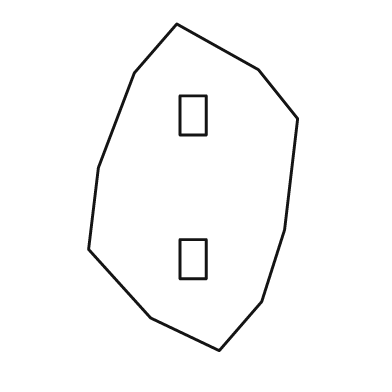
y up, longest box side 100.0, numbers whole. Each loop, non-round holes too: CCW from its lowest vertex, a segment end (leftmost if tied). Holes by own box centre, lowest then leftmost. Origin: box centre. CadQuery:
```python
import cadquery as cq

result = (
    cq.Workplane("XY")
    .moveTo(8.0, -50.0)
    .lineTo(21.0, -35.0)
    .lineTo(28.0, -13.0)
    .lineTo(32.0, 21.0)
    .lineTo(20.0, 36.0)
    .lineTo(-5.0, 50.0)
    .lineTo(-18.0, 35.0)
    .lineTo(-29.0, 6.0)
    .lineTo(-32.0, -19.0)
    .lineTo(-13.0, -40.0)
    .close()
    .moveTo(-4.0, -28.0)
    .lineTo(4.0, -28.0)
    .lineTo(4.0, -16.0)
    .lineTo(-4.0, -16.0)
    .close()
    .moveTo(-4.0, 16.0)
    .lineTo(4.0, 16.0)
    .lineTo(4.0, 28.0)
    .lineTo(-4.0, 28.0)
    .close()
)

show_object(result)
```